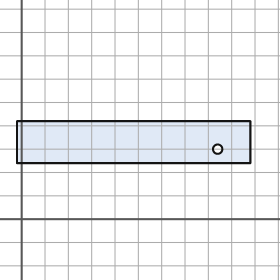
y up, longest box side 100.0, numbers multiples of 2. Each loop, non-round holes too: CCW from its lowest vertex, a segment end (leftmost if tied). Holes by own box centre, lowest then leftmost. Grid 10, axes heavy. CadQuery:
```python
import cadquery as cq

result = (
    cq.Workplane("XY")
    .moveTo(-2.0, 24.0)
    .lineTo(98.0, 24.0)
    .lineTo(98.0, 42.0)
    .lineTo(-2.0, 42.0)
    .close()
    .moveTo(84.0, 30.0)
    .circle(2.0)
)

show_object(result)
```